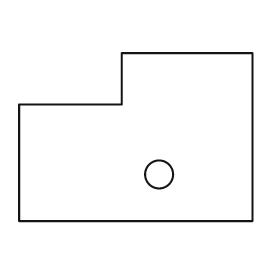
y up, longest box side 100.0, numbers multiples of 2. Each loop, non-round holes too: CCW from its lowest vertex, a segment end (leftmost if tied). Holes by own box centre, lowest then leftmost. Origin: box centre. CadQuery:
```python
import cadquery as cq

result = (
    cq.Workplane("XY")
    .moveTo(-50.0, -36.0)
    .lineTo(50.0, -36.0)
    .lineTo(50.0, 36.0)
    .lineTo(-6.0, 36.0)
    .lineTo(-6.0, 14.0)
    .lineTo(-50.0, 14.0)
    .close()
    .moveTo(10.0, -16.0)
    .circle(6.0)
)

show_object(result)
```